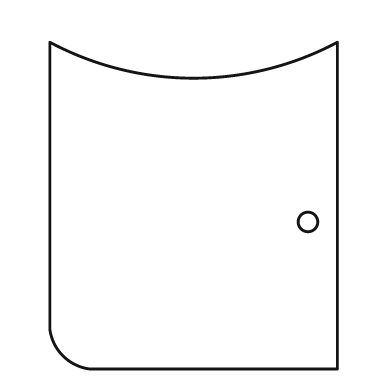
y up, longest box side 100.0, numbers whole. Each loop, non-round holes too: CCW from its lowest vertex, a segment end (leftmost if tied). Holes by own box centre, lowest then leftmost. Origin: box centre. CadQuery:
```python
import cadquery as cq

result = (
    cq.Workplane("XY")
    .moveTo(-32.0, -50.0)
    .lineTo(44.0, -50.0)
    .lineTo(44.0, 50.0)
    .threePointArc((0.0, 39.0), (-44.0, 50.0))
    .lineTo(-44.0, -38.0)
    .threePointArc((-40.0, -46.0), (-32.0, -50.0))
    .close()
    .moveTo(35.0, -5.0)
    .circle(3.0)
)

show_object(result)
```